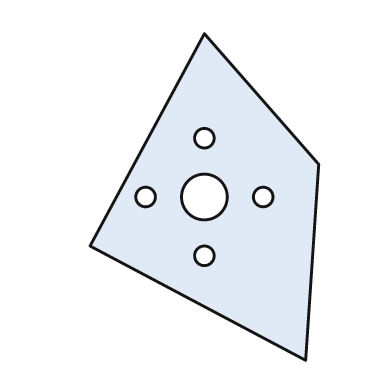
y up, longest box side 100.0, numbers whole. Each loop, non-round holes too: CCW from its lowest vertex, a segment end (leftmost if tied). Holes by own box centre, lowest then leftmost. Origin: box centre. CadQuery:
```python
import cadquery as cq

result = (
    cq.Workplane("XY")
    .moveTo(31.0, -50.0)
    .lineTo(35.0, 10.0)
    .lineTo(0.0, 50.0)
    .lineTo(-35.0, -15.0)
    .close()
    .moveTo(0.0, -18.0)
    .circle(3.0)
    .moveTo(-18.0, 0.0)
    .circle(3.0)
    .moveTo(0.0, 0.0)
    .circle(7.0)
    .moveTo(18.0, 0.0)
    .circle(3.0)
    .moveTo(0.0, 18.0)
    .circle(3.0)
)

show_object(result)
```